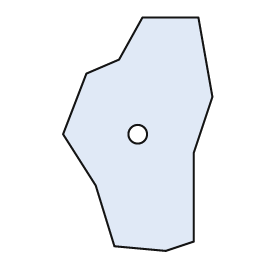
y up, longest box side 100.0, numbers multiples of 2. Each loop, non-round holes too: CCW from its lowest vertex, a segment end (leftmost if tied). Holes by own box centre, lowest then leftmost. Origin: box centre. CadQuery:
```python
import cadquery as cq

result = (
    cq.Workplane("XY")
    .moveTo(12.0, -50.0)
    .lineTo(24.0, -46.0)
    .lineTo(24.0, -8.0)
    .lineTo(32.0, 16.0)
    .lineTo(26.0, 50.0)
    .lineTo(2.0, 50.0)
    .lineTo(-8.0, 32.0)
    .lineTo(-22.0, 26.0)
    .lineTo(-32.0, 0.0)
    .lineTo(-18.0, -22.0)
    .lineTo(-10.0, -48.0)
    .close()
    .moveTo(0.0, 0.0)
    .circle(4.0)
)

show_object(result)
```